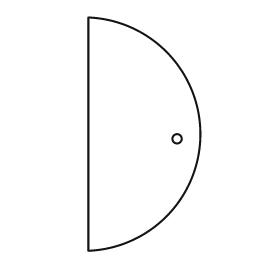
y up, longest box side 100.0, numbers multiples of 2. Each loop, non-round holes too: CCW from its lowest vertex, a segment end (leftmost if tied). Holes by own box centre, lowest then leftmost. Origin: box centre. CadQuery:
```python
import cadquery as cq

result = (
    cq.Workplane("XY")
    .moveTo(-24.0, -50.0)
    .threePointArc((24.0, 0.0), (-24.0, 50.0))
    .close()
    .moveTo(14.0, -2.0)
    .circle(2.0)
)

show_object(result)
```